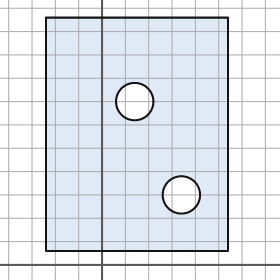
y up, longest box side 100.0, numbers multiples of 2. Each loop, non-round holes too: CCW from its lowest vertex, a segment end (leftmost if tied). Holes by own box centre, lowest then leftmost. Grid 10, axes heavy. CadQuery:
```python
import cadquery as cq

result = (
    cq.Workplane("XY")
    .moveTo(-24.0, 6.0)
    .lineTo(54.0, 6.0)
    .lineTo(54.0, 106.0)
    .lineTo(-24.0, 106.0)
    .close()
    .moveTo(34.0, 30.0)
    .circle(8.0)
    .moveTo(14.0, 70.0)
    .circle(8.0)
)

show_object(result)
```